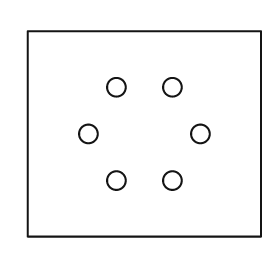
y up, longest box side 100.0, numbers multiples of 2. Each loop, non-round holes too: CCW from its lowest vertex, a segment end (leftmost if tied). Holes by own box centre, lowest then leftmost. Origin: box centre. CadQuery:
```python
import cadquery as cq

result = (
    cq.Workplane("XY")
    .moveTo(-50.0, -44.0)
    .lineTo(50.0, -44.0)
    .lineTo(50.0, 44.0)
    .lineTo(-50.0, 44.0)
    .close()
    .moveTo(-12.0, -20.0)
    .circle(4.0)
    .moveTo(12.0, -20.0)
    .circle(4.0)
    .moveTo(-24.0, 0.0)
    .circle(4.0)
    .moveTo(24.0, 0.0)
    .circle(4.0)
    .moveTo(-12.0, 20.0)
    .circle(4.0)
    .moveTo(12.0, 20.0)
    .circle(4.0)
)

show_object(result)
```